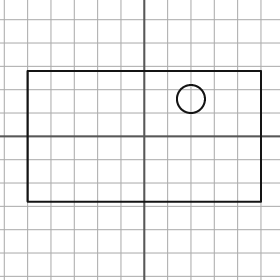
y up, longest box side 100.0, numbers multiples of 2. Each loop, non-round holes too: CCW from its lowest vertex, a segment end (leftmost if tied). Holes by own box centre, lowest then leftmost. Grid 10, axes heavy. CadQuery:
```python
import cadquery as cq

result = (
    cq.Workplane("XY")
    .moveTo(-50.0, -28.0)
    .lineTo(50.0, -28.0)
    .lineTo(50.0, 28.0)
    .lineTo(-50.0, 28.0)
    .close()
    .moveTo(20.0, 16.0)
    .circle(6.0)
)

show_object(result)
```